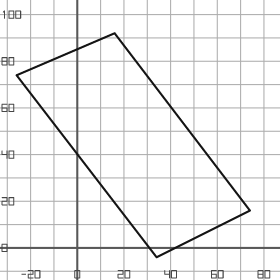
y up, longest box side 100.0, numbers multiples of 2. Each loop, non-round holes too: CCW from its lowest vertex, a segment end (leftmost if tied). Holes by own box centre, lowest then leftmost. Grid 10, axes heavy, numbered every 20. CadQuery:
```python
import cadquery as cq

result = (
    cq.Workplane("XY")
    .moveTo(34.0, -4.0)
    .lineTo(74.0, 16.0)
    .lineTo(16.0, 92.0)
    .lineTo(-26.0, 74.0)
    .close()
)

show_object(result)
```